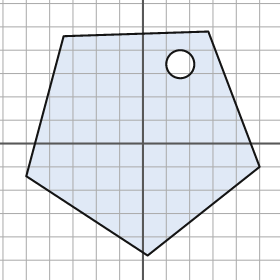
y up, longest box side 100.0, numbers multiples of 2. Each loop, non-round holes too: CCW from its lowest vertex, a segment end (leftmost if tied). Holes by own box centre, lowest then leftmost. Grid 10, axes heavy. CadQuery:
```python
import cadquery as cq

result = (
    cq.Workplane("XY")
    .moveTo(2.0, -48.0)
    .lineTo(50.0, -10.0)
    .lineTo(28.0, 48.0)
    .lineTo(-34.0, 46.0)
    .lineTo(-50.0, -14.0)
    .close()
    .moveTo(16.0, 34.0)
    .circle(6.0)
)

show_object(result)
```